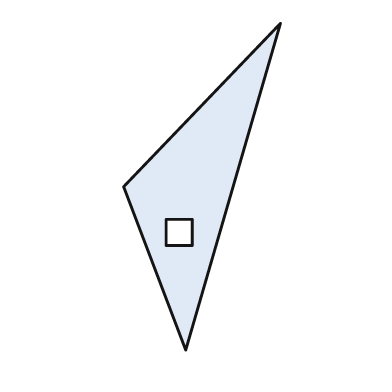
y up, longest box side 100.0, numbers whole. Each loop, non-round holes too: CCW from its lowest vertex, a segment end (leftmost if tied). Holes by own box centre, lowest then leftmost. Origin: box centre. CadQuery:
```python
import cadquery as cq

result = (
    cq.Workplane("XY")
    .moveTo(-5.0, -50.0)
    .lineTo(24.0, 50.0)
    .lineTo(-24.0, 0.0)
    .close()
    .moveTo(-11.0, -18.0)
    .lineTo(-3.0, -18.0)
    .lineTo(-3.0, -10.0)
    .lineTo(-11.0, -10.0)
    .close()
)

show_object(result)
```